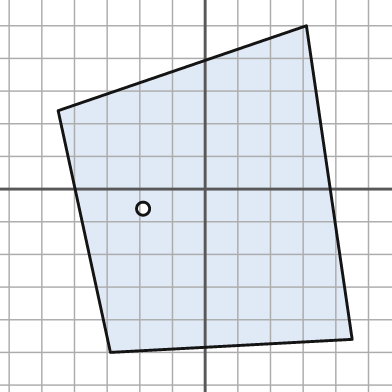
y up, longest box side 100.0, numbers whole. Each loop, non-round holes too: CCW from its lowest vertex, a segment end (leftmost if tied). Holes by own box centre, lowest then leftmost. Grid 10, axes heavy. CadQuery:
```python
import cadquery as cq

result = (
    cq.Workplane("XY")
    .moveTo(-29.0, -50.0)
    .lineTo(45.0, -46.0)
    .lineTo(31.0, 50.0)
    .lineTo(-45.0, 24.0)
    .close()
    .moveTo(-19.0, -6.0)
    .circle(2.0)
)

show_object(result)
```